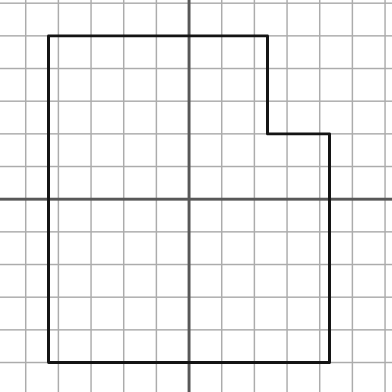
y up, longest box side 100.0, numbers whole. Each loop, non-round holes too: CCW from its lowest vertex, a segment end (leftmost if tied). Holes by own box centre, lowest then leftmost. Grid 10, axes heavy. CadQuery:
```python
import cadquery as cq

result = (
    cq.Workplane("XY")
    .moveTo(-43.0, -50.0)
    .lineTo(43.0, -50.0)
    .lineTo(43.0, 20.0)
    .lineTo(24.0, 20.0)
    .lineTo(24.0, 50.0)
    .lineTo(-43.0, 50.0)
    .close()
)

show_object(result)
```